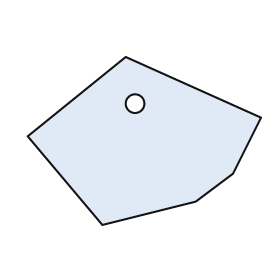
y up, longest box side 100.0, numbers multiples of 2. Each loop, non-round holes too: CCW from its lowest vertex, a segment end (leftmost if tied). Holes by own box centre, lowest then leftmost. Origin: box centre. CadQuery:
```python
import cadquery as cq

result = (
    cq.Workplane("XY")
    .moveTo(-18.0, -36.0)
    .lineTo(22.0, -26.0)
    .lineTo(38.0, -14.0)
    .lineTo(50.0, 10.0)
    .lineTo(-8.0, 36.0)
    .lineTo(-50.0, 2.0)
    .close()
    .moveTo(-4.0, 16.0)
    .circle(4.0)
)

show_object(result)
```